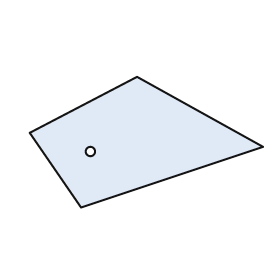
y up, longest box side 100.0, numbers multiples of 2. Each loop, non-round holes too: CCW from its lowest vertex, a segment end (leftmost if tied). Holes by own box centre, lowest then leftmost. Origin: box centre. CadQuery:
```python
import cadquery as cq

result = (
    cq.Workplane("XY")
    .moveTo(-28.0, -28.0)
    .lineTo(50.0, -2.0)
    .lineTo(-4.0, 28.0)
    .lineTo(-50.0, 4.0)
    .close()
    .moveTo(-24.0, -4.0)
    .circle(2.0)
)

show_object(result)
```